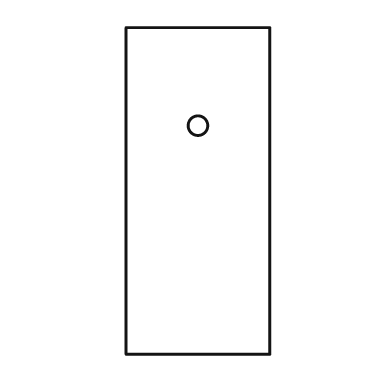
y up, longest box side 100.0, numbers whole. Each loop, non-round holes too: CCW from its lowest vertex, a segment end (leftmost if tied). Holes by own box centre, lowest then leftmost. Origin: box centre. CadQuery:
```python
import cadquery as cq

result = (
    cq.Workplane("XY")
    .moveTo(-22.0, -50.0)
    .lineTo(22.0, -50.0)
    .lineTo(22.0, 50.0)
    .lineTo(-22.0, 50.0)
    .close()
    .moveTo(0.0, 20.0)
    .circle(3.0)
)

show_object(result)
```